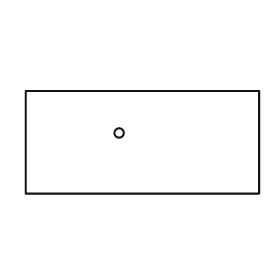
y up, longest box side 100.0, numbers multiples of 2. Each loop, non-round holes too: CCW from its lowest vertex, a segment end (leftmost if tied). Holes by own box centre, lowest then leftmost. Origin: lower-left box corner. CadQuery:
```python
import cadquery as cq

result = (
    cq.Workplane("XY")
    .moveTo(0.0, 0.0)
    .lineTo(100.0, 0.0)
    .lineTo(100.0, 44.0)
    .lineTo(0.0, 44.0)
    .close()
    .moveTo(40.0, 26.0)
    .circle(2.0)
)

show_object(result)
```